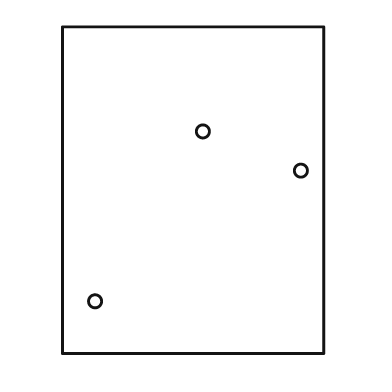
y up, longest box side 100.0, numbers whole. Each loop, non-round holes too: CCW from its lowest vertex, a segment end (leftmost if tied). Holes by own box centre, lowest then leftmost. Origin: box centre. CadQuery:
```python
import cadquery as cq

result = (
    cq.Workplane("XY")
    .moveTo(-40.0, -50.0)
    .lineTo(40.0, -50.0)
    .lineTo(40.0, 50.0)
    .lineTo(-40.0, 50.0)
    .close()
    .moveTo(-30.0, -34.0)
    .circle(2.0)
    .moveTo(33.0, 6.0)
    .circle(2.0)
    .moveTo(3.0, 18.0)
    .circle(2.0)
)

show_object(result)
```